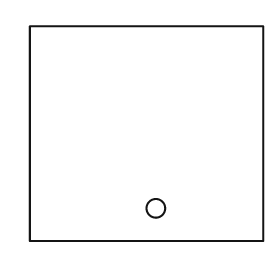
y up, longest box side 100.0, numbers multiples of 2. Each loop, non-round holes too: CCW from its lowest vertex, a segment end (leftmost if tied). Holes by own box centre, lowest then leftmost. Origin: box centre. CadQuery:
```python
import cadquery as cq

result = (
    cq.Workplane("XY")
    .moveTo(-50.0, -46.0)
    .lineTo(50.0, -46.0)
    .lineTo(50.0, 46.0)
    .lineTo(-50.0, 46.0)
    .close()
    .moveTo(4.0, -32.0)
    .circle(4.0)
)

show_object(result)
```